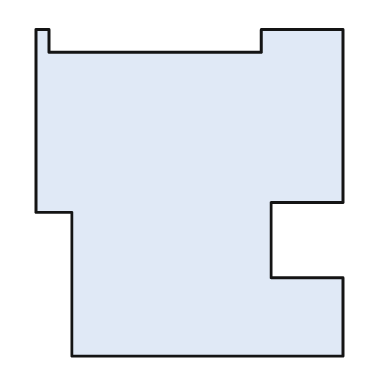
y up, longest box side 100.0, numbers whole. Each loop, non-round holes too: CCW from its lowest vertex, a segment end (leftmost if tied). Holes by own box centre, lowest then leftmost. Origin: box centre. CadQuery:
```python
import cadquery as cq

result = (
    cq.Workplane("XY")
    .moveTo(-36.0, -50.0)
    .lineTo(47.0, -50.0)
    .lineTo(47.0, -26.0)
    .lineTo(25.0, -26.0)
    .lineTo(25.0, -3.0)
    .lineTo(47.0, -3.0)
    .lineTo(47.0, 50.0)
    .lineTo(22.0, 50.0)
    .lineTo(22.0, 43.0)
    .lineTo(-43.0, 43.0)
    .lineTo(-43.0, 50.0)
    .lineTo(-47.0, 50.0)
    .lineTo(-47.0, -6.0)
    .lineTo(-36.0, -6.0)
    .close()
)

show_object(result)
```